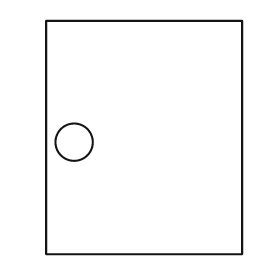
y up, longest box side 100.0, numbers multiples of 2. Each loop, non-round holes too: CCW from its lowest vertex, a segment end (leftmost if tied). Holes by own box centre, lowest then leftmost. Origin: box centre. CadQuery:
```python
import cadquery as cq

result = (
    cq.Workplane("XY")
    .moveTo(-42.0, -50.0)
    .lineTo(42.0, -50.0)
    .lineTo(42.0, 50.0)
    .lineTo(-42.0, 50.0)
    .close()
    .moveTo(-30.0, -2.0)
    .circle(8.0)
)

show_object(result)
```